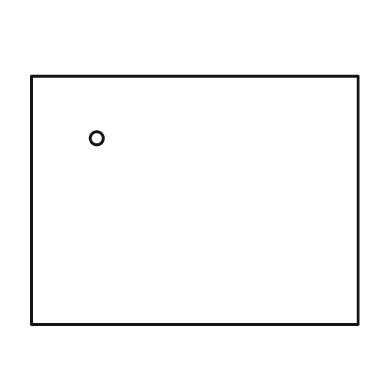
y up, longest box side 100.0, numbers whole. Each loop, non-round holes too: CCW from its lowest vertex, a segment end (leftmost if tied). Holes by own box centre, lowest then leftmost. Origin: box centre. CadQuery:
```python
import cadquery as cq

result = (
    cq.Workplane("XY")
    .moveTo(-50.0, -38.0)
    .lineTo(50.0, -38.0)
    .lineTo(50.0, 38.0)
    .lineTo(-50.0, 38.0)
    .close()
    .moveTo(-30.0, 19.0)
    .circle(2.0)
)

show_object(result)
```